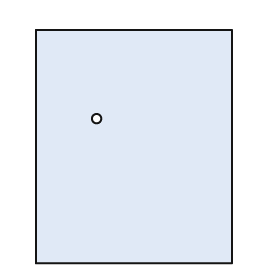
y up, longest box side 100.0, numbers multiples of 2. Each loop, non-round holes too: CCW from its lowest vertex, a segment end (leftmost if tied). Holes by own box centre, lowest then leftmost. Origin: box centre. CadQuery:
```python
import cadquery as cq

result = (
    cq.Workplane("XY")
    .moveTo(-42.0, -50.0)
    .lineTo(42.0, -50.0)
    .lineTo(42.0, 50.0)
    .lineTo(-42.0, 50.0)
    .close()
    .moveTo(-16.0, 12.0)
    .circle(2.0)
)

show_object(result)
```